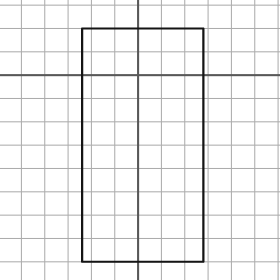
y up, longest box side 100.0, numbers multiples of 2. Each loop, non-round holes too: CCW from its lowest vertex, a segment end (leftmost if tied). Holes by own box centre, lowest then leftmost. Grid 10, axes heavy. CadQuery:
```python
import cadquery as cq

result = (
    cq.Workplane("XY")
    .moveTo(-24.0, -80.0)
    .lineTo(28.0, -80.0)
    .lineTo(28.0, 20.0)
    .lineTo(-24.0, 20.0)
    .close()
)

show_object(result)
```